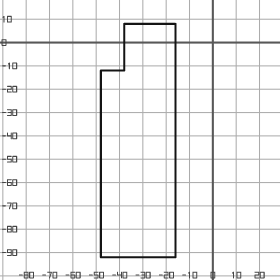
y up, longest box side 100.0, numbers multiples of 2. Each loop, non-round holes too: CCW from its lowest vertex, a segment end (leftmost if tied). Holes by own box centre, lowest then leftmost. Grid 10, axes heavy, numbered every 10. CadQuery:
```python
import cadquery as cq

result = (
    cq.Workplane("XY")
    .moveTo(-48.0, -92.0)
    .lineTo(-16.0, -92.0)
    .lineTo(-16.0, 8.0)
    .lineTo(-38.0, 8.0)
    .lineTo(-38.0, -12.0)
    .lineTo(-48.0, -12.0)
    .close()
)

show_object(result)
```